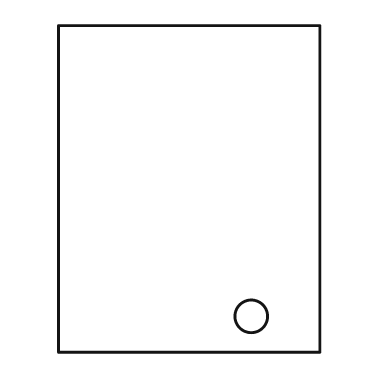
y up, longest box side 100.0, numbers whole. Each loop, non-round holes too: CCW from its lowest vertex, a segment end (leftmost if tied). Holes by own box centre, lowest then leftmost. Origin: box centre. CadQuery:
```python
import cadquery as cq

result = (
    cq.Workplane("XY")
    .moveTo(-40.0, -50.0)
    .lineTo(40.0, -50.0)
    .lineTo(40.0, 50.0)
    .lineTo(-40.0, 50.0)
    .close()
    .moveTo(19.0, -39.0)
    .circle(5.0)
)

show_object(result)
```